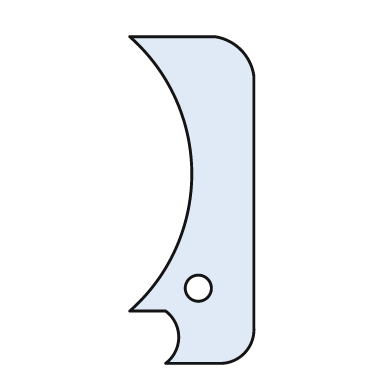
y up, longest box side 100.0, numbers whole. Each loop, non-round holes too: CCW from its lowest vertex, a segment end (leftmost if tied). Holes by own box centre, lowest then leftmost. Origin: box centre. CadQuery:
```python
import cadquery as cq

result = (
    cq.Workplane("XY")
    .moveTo(-8.0, -50.0)
    .lineTo(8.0, -50.0)
    .threePointArc((16.0, -47.0), (19.0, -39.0))
    .lineTo(19.0, 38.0)
    .threePointArc((15.0, 46.0), (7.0, 50.0))
    .lineTo(-19.0, 50.0)
    .threePointArc((0.0, 8.0), (-19.0, -34.0))
    .lineTo(-8.0, -34.0)
    .threePointArc((-4.0, -42.0), (-8.0, -50.0))
    .close()
    .moveTo(2.0, -27.0)
    .circle(4.0)
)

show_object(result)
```